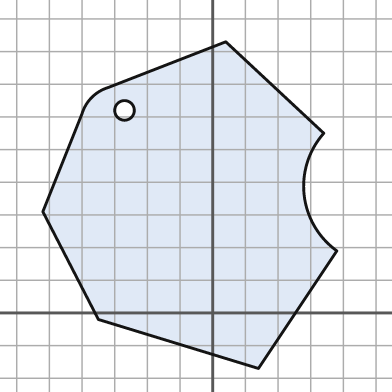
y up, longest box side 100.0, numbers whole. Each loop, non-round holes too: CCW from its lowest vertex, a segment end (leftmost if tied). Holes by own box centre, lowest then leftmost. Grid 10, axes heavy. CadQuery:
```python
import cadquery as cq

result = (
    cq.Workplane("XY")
    .moveTo(14.0, -17.0)
    .lineTo(38.0, 19.0)
    .threePointArc((28.0, 36.0), (34.0, 55.0))
    .lineTo(4.0, 83.0)
    .lineTo(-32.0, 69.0)
    .threePointArc((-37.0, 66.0), (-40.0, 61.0))
    .lineTo(-52.0, 31.0)
    .lineTo(-35.0, -2.0)
    .close()
    .moveTo(-27.0, 62.0)
    .circle(3.0)
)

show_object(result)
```